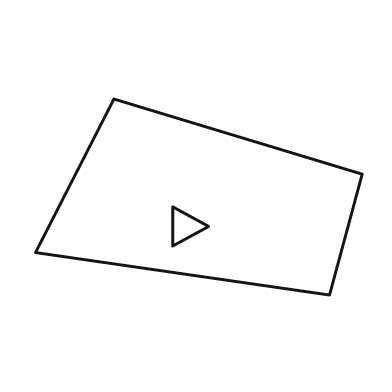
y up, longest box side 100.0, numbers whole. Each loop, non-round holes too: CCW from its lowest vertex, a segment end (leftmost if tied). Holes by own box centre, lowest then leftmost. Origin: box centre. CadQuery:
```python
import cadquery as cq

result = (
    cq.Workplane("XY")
    .moveTo(40.0, -30.0)
    .lineTo(50.0, 7.0)
    .lineTo(-26.0, 30.0)
    .lineTo(-50.0, -17.0)
    .close()
    .moveTo(-8.0, -15.0)
    .lineTo(3.0, -9.0)
    .lineTo(-8.0, -3.0)
    .close()
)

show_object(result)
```